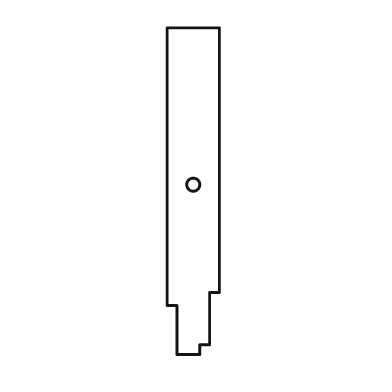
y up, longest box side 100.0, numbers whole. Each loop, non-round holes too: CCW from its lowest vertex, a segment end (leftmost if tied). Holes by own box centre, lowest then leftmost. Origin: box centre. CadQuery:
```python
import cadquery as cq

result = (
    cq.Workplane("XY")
    .moveTo(-5.0, -50.0)
    .lineTo(2.0, -50.0)
    .lineTo(2.0, -47.0)
    .lineTo(5.0, -47.0)
    .lineTo(5.0, -31.0)
    .lineTo(8.0, -31.0)
    .lineTo(8.0, 50.0)
    .lineTo(-8.0, 50.0)
    .lineTo(-8.0, -35.0)
    .lineTo(-5.0, -35.0)
    .close()
    .moveTo(0.0, 2.0)
    .circle(2.0)
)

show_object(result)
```